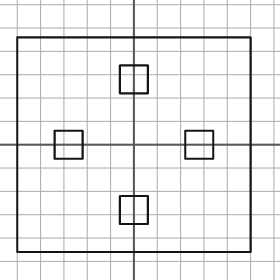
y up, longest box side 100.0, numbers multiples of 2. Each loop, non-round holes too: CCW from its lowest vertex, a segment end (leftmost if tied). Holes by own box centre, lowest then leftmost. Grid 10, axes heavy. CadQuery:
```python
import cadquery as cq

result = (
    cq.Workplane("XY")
    .moveTo(-50.0, -46.0)
    .lineTo(50.0, -46.0)
    .lineTo(50.0, 46.0)
    .lineTo(-50.0, 46.0)
    .close()
    .moveTo(-6.0, -34.0)
    .lineTo(6.0, -34.0)
    .lineTo(6.0, -22.0)
    .lineTo(-6.0, -22.0)
    .close()
    .moveTo(-34.0, -6.0)
    .lineTo(-22.0, -6.0)
    .lineTo(-22.0, 6.0)
    .lineTo(-34.0, 6.0)
    .close()
    .moveTo(22.0, -6.0)
    .lineTo(34.0, -6.0)
    .lineTo(34.0, 6.0)
    .lineTo(22.0, 6.0)
    .close()
    .moveTo(-6.0, 22.0)
    .lineTo(6.0, 22.0)
    .lineTo(6.0, 34.0)
    .lineTo(-6.0, 34.0)
    .close()
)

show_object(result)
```